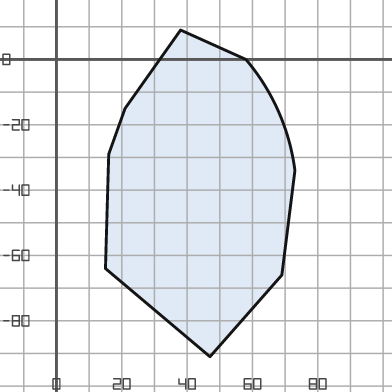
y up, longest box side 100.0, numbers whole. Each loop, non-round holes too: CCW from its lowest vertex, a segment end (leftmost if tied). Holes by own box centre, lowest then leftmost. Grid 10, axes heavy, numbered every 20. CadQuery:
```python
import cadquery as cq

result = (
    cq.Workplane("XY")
    .moveTo(47.0, -91.0)
    .lineTo(69.0, -66.0)
    .lineTo(73.0, -34.0)
    .threePointArc((68.0, -16.0), (58.0, 0.0))
    .lineTo(38.0, 9.0)
    .lineTo(21.0, -15.0)
    .lineTo(16.0, -29.0)
    .lineTo(15.0, -64.0)
    .close()
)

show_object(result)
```